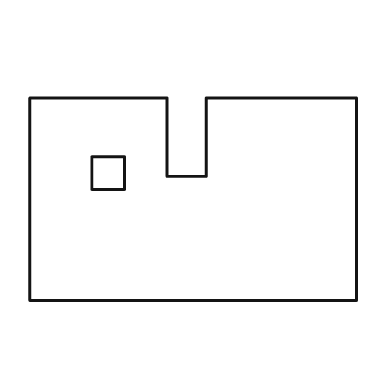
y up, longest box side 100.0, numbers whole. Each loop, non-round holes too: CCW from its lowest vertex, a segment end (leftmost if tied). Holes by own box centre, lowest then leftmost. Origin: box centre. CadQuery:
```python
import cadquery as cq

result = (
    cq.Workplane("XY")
    .moveTo(-50.0, -31.0)
    .lineTo(50.0, -31.0)
    .lineTo(50.0, 31.0)
    .lineTo(4.0, 31.0)
    .lineTo(4.0, 7.0)
    .lineTo(-8.0, 7.0)
    .lineTo(-8.0, 31.0)
    .lineTo(-50.0, 31.0)
    .close()
    .moveTo(-31.0, 3.0)
    .lineTo(-21.0, 3.0)
    .lineTo(-21.0, 13.0)
    .lineTo(-31.0, 13.0)
    .close()
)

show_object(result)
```